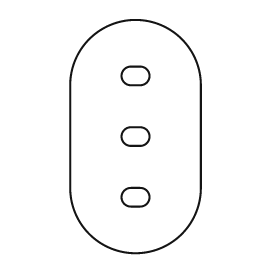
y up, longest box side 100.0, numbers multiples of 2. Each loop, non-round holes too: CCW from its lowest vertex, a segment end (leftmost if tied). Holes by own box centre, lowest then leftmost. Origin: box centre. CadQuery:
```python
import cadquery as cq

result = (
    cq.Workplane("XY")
    .moveTo(-28.0, -22.0)
    .threePointArc((0.0, -50.0), (28.0, -22.0))
    .lineTo(28.0, 22.0)
    .threePointArc((0.0, 50.0), (-28.0, 22.0))
    .close()
    .moveTo(-2.0, -30.0)
    .lineTo(2.0, -30.0)
    .threePointArc((6.0, -26.0), (2.0, -22.0))
    .lineTo(-2.0, -22.0)
    .threePointArc((-6.0, -26.0), (-2.0, -30.0))
    .close()
    .moveTo(-2.0, -4.0)
    .lineTo(2.0, -4.0)
    .threePointArc((6.0, 0.0), (2.0, 4.0))
    .lineTo(-2.0, 4.0)
    .threePointArc((-6.0, 0.0), (-2.0, -4.0))
    .close()
    .moveTo(-2.0, 22.0)
    .lineTo(2.0, 22.0)
    .threePointArc((6.0, 26.0), (2.0, 30.0))
    .lineTo(-2.0, 30.0)
    .threePointArc((-6.0, 26.0), (-2.0, 22.0))
    .close()
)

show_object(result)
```